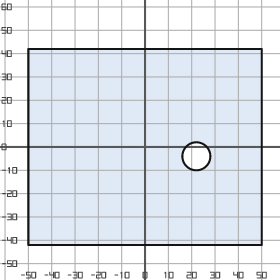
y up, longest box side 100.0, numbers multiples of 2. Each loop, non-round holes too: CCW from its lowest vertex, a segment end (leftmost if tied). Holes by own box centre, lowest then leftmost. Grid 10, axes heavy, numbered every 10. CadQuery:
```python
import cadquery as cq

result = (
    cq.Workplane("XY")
    .moveTo(-50.0, -42.0)
    .lineTo(50.0, -42.0)
    .lineTo(50.0, 42.0)
    .lineTo(-50.0, 42.0)
    .close()
    .moveTo(22.0, -4.0)
    .circle(6.0)
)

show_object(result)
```